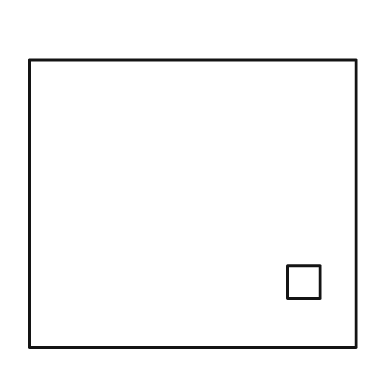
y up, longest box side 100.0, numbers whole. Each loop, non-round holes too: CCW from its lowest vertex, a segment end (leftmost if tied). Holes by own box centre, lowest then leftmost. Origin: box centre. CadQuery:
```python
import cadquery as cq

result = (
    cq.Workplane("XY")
    .moveTo(-50.0, -44.0)
    .lineTo(50.0, -44.0)
    .lineTo(50.0, 44.0)
    .lineTo(-50.0, 44.0)
    .close()
    .moveTo(29.0, -29.0)
    .lineTo(39.0, -29.0)
    .lineTo(39.0, -19.0)
    .lineTo(29.0, -19.0)
    .close()
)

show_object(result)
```